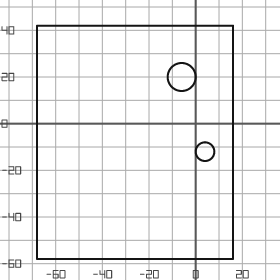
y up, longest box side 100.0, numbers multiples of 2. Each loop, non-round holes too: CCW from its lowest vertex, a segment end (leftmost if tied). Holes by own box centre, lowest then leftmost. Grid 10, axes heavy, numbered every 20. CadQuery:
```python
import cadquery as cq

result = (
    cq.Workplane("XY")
    .moveTo(-68.0, -58.0)
    .lineTo(16.0, -58.0)
    .lineTo(16.0, 42.0)
    .lineTo(-68.0, 42.0)
    .close()
    .moveTo(4.0, -12.0)
    .circle(4.0)
    .moveTo(-6.0, 20.0)
    .circle(6.0)
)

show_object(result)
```